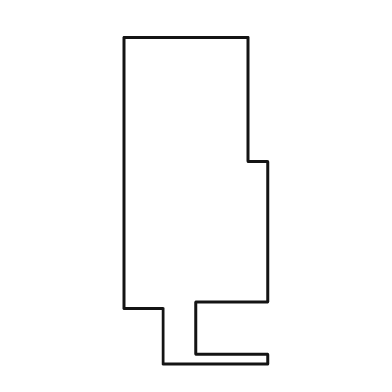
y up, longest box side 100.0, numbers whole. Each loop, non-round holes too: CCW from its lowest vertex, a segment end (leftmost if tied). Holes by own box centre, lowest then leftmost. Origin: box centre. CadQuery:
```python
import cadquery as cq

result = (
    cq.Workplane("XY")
    .moveTo(-10.0, -50.0)
    .lineTo(22.0, -50.0)
    .lineTo(22.0, -47.0)
    .lineTo(0.0, -47.0)
    .lineTo(0.0, -31.0)
    .lineTo(22.0, -31.0)
    .lineTo(22.0, 12.0)
    .lineTo(16.0, 12.0)
    .lineTo(16.0, 50.0)
    .lineTo(-22.0, 50.0)
    .lineTo(-22.0, -33.0)
    .lineTo(-10.0, -33.0)
    .close()
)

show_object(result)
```